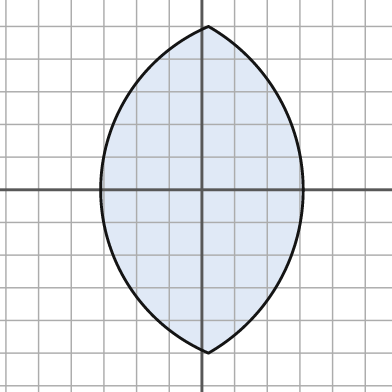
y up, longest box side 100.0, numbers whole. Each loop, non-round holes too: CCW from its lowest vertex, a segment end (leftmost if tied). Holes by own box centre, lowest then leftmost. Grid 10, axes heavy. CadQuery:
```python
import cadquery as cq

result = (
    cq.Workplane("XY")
    .moveTo(2.0, -50.0)
    .threePointArc((31.0, 0.0), (2.0, 50.0))
    .threePointArc((-31.0, 0.0), (2.0, -50.0))
    .close()
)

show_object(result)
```